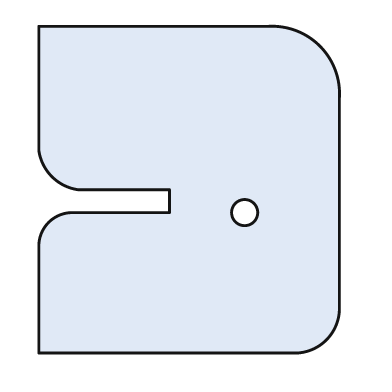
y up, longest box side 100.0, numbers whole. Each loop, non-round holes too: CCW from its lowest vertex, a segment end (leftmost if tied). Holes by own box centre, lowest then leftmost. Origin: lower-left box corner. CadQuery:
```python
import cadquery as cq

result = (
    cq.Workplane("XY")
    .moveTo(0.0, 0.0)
    .lineTo(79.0, 0.0)
    .threePointArc((88.0, 4.0), (92.0, 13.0))
    .lineTo(92.0, 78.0)
    .threePointArc((86.0, 94.0), (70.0, 100.0))
    .lineTo(0.0, 100.0)
    .lineTo(0.0, 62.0)
    .threePointArc((4.0, 54.0), (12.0, 50.0))
    .lineTo(40.0, 50.0)
    .lineTo(40.0, 43.0)
    .lineTo(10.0, 43.0)
    .threePointArc((3.0, 40.0), (0.0, 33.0))
    .close()
    .moveTo(63.0, 43.0)
    .circle(4.0)
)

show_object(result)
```